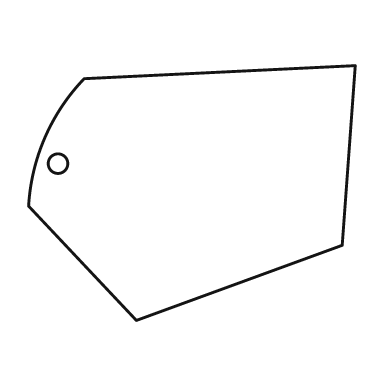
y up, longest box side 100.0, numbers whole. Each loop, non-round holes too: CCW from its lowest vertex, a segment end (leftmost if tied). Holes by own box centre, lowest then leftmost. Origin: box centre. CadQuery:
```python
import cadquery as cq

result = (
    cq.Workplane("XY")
    .moveTo(-17.0, -39.0)
    .lineTo(46.0, -16.0)
    .lineTo(50.0, 39.0)
    .lineTo(-33.0, 35.0)
    .threePointArc((-45.0, 17.0), (-50.0, -4.0))
    .close()
    .moveTo(-41.0, 9.0)
    .circle(3.0)
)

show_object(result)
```